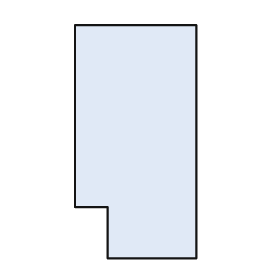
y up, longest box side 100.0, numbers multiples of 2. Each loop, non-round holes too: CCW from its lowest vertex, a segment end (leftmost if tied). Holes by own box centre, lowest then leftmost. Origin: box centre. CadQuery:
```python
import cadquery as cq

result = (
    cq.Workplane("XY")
    .moveTo(-12.0, -50.0)
    .lineTo(26.0, -50.0)
    .lineTo(26.0, 50.0)
    .lineTo(-26.0, 50.0)
    .lineTo(-26.0, -28.0)
    .lineTo(-12.0, -28.0)
    .close()
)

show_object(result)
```